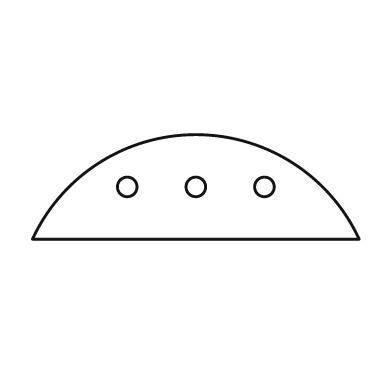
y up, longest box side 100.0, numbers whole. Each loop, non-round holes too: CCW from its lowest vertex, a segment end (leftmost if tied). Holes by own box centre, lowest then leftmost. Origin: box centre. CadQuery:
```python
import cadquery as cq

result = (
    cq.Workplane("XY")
    .moveTo(-50.0, -16.0)
    .lineTo(50.0, -16.0)
    .threePointArc((0.0, 16.0), (-50.0, -16.0))
    .close()
    .moveTo(-21.0, 0.0)
    .circle(3.0)
    .moveTo(0.0, 0.0)
    .circle(3.0)
    .moveTo(21.0, 0.0)
    .circle(3.0)
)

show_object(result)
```